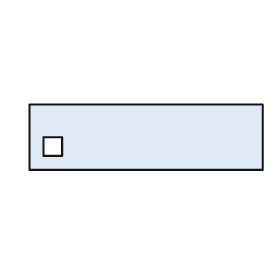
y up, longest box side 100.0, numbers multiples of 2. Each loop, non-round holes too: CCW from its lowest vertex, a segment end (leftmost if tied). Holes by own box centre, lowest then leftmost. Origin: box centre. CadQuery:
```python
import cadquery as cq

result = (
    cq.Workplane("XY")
    .moveTo(-50.0, -14.0)
    .lineTo(50.0, -14.0)
    .lineTo(50.0, 14.0)
    .lineTo(-50.0, 14.0)
    .close()
    .moveTo(-44.0, -8.0)
    .lineTo(-36.0, -8.0)
    .lineTo(-36.0, 0.0)
    .lineTo(-44.0, 0.0)
    .close()
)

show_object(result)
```